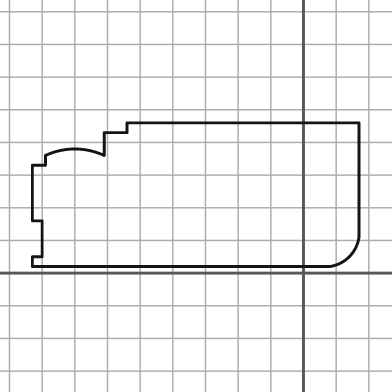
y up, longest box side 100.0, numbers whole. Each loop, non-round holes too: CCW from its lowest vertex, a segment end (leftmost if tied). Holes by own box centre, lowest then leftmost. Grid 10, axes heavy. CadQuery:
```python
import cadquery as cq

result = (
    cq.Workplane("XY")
    .moveTo(-83.0, 2.0)
    .lineTo(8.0, 2.0)
    .threePointArc((14.0, 5.0), (17.0, 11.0))
    .lineTo(17.0, 46.0)
    .lineTo(-54.0, 46.0)
    .lineTo(-54.0, 43.0)
    .lineTo(-61.0, 43.0)
    .lineTo(-61.0, 36.0)
    .threePointArc((-70.0, 38.0), (-79.0, 36.0))
    .lineTo(-79.0, 33.0)
    .lineTo(-83.0, 33.0)
    .lineTo(-83.0, 16.0)
    .lineTo(-80.0, 16.0)
    .lineTo(-80.0, 5.0)
    .lineTo(-83.0, 5.0)
    .close()
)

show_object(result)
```